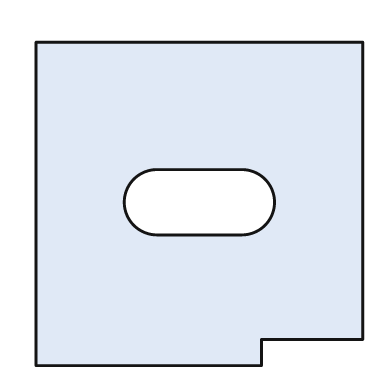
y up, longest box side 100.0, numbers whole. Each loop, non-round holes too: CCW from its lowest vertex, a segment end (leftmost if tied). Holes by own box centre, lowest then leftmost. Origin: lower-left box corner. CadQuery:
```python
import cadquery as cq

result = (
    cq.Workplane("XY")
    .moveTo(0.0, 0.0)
    .lineTo(69.0, 0.0)
    .lineTo(69.0, 8.0)
    .lineTo(100.0, 8.0)
    .lineTo(100.0, 99.0)
    .lineTo(0.0, 99.0)
    .close()
    .moveTo(37.0, 40.0)
    .lineTo(63.0, 40.0)
    .threePointArc((73.0, 50.0), (63.0, 60.0))
    .lineTo(37.0, 60.0)
    .threePointArc((27.0, 50.0), (37.0, 40.0))
    .close()
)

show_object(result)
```